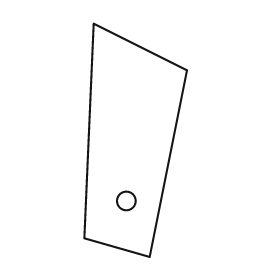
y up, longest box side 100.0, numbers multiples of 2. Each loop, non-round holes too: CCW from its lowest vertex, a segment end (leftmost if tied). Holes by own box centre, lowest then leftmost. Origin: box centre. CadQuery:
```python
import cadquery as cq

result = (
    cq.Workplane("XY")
    .moveTo(6.0, -50.0)
    .lineTo(22.0, 30.0)
    .lineTo(-18.0, 50.0)
    .lineTo(-22.0, -42.0)
    .close()
    .moveTo(-4.0, -26.0)
    .circle(4.0)
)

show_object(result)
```